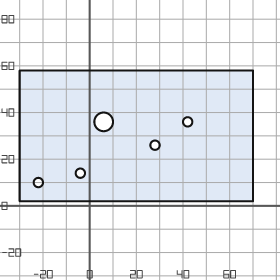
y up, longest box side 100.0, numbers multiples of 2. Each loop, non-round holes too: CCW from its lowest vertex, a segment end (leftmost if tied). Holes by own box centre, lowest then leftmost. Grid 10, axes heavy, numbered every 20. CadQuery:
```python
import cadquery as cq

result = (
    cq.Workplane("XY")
    .moveTo(-30.0, 2.0)
    .lineTo(70.0, 2.0)
    .lineTo(70.0, 58.0)
    .lineTo(-30.0, 58.0)
    .close()
    .moveTo(-22.0, 10.0)
    .circle(2.0)
    .moveTo(-4.0, 14.0)
    .circle(2.0)
    .moveTo(28.0, 26.0)
    .circle(2.0)
    .moveTo(6.0, 36.0)
    .circle(4.0)
    .moveTo(42.0, 36.0)
    .circle(2.0)
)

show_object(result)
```